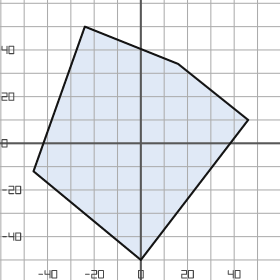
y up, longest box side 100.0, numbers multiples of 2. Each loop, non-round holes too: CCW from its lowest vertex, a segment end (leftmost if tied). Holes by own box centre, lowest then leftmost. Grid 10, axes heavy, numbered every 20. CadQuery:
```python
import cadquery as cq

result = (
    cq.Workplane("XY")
    .moveTo(0.0, -50.0)
    .lineTo(46.0, 10.0)
    .lineTo(16.0, 34.0)
    .lineTo(-24.0, 50.0)
    .lineTo(-46.0, -12.0)
    .close()
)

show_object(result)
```